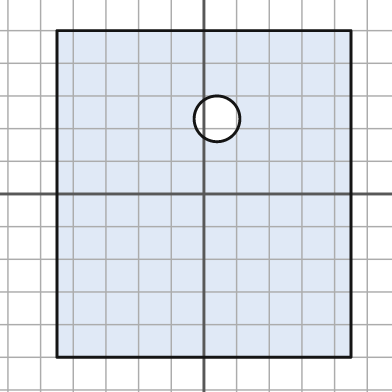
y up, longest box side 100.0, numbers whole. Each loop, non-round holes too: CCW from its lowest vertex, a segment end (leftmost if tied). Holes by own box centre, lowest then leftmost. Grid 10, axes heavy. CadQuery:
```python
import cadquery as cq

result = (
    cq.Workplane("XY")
    .moveTo(-45.0, -50.0)
    .lineTo(45.0, -50.0)
    .lineTo(45.0, 50.0)
    .lineTo(-45.0, 50.0)
    .close()
    .moveTo(4.0, 23.0)
    .circle(7.0)
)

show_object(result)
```